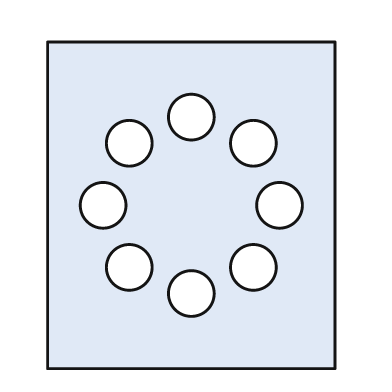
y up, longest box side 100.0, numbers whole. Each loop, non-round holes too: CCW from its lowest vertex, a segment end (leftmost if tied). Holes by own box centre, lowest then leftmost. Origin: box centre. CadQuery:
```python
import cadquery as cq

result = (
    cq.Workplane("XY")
    .moveTo(-44.0, -50.0)
    .lineTo(44.0, -50.0)
    .lineTo(44.0, 50.0)
    .lineTo(-44.0, 50.0)
    .close()
    .moveTo(0.0, -27.0)
    .circle(7.0)
    .moveTo(-19.0, -19.0)
    .circle(7.0)
    .moveTo(19.0, -19.0)
    .circle(7.0)
    .moveTo(-27.0, 0.0)
    .circle(7.0)
    .moveTo(27.0, 0.0)
    .circle(7.0)
    .moveTo(-19.0, 19.0)
    .circle(7.0)
    .moveTo(19.0, 19.0)
    .circle(7.0)
    .moveTo(0.0, 27.0)
    .circle(7.0)
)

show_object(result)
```